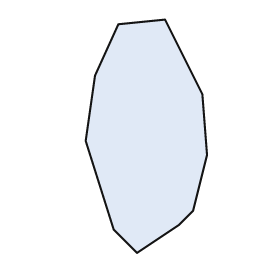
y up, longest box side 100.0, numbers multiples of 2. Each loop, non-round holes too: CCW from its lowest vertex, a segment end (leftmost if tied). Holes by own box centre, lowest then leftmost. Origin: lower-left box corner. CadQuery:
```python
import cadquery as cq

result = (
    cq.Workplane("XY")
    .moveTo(22.0, 0.0)
    .lineTo(40.0, 12.0)
    .lineTo(46.0, 18.0)
    .lineTo(52.0, 42.0)
    .lineTo(50.0, 68.0)
    .lineTo(34.0, 100.0)
    .lineTo(14.0, 98.0)
    .lineTo(4.0, 76.0)
    .lineTo(0.0, 48.0)
    .lineTo(12.0, 10.0)
    .close()
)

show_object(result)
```